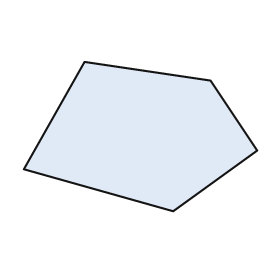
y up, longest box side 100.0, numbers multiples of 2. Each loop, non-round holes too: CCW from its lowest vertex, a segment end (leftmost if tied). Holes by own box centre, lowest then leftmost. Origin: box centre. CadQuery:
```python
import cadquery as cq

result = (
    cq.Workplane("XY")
    .moveTo(14.0, -32.0)
    .lineTo(50.0, -6.0)
    .lineTo(30.0, 24.0)
    .lineTo(-24.0, 32.0)
    .lineTo(-50.0, -14.0)
    .close()
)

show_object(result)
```